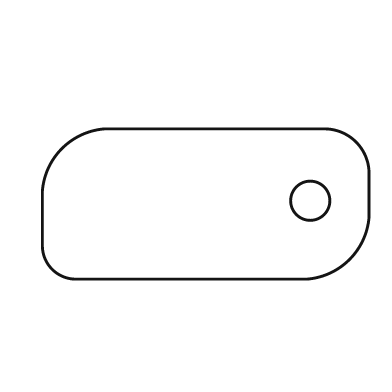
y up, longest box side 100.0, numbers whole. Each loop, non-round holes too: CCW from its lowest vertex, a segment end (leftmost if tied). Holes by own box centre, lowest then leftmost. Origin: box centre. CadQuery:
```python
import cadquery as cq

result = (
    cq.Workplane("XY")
    .moveTo(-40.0, -23.0)
    .lineTo(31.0, -23.0)
    .threePointArc((44.0, -17.0), (50.0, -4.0))
    .lineTo(50.0, 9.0)
    .threePointArc((46.0, 19.0), (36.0, 23.0))
    .lineTo(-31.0, 23.0)
    .threePointArc((-44.0, 17.0), (-50.0, 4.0))
    .lineTo(-50.0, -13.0)
    .threePointArc((-47.0, -20.0), (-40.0, -23.0))
    .close()
    .moveTo(32.0, 1.0)
    .circle(6.0)
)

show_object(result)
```